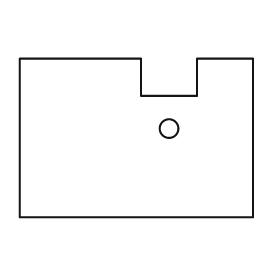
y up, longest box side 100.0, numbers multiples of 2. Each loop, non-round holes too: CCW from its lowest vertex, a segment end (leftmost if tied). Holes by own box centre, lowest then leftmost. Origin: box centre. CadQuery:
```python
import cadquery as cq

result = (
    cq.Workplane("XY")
    .moveTo(-50.0, -34.0)
    .lineTo(50.0, -34.0)
    .lineTo(50.0, 34.0)
    .lineTo(26.0, 34.0)
    .lineTo(26.0, 18.0)
    .lineTo(2.0, 18.0)
    .lineTo(2.0, 34.0)
    .lineTo(-50.0, 34.0)
    .close()
    .moveTo(14.0, 4.0)
    .circle(4.0)
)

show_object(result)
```